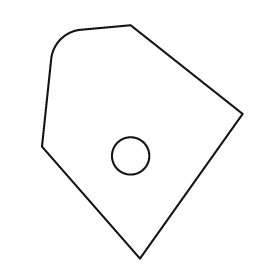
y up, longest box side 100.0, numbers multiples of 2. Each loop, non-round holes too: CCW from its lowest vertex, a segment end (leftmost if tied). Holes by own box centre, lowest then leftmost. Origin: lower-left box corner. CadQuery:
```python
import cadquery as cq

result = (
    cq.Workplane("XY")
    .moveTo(42.0, 0.0)
    .lineTo(86.0, 62.0)
    .lineTo(38.0, 100.0)
    .lineTo(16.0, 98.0)
    .threePointArc((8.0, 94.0), (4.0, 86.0))
    .lineTo(0.0, 48.0)
    .close()
    .moveTo(38.0, 44.0)
    .circle(8.0)
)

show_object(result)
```